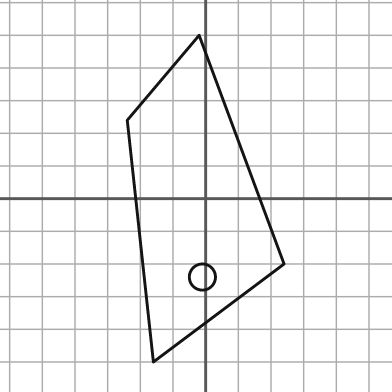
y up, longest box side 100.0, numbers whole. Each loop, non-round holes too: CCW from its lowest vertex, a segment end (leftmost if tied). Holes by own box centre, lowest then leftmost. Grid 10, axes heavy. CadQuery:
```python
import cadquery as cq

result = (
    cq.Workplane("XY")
    .moveTo(-16.0, -50.0)
    .lineTo(24.0, -20.0)
    .lineTo(-2.0, 50.0)
    .lineTo(-24.0, 24.0)
    .close()
    .moveTo(-1.0, -24.0)
    .circle(4.0)
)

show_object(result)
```